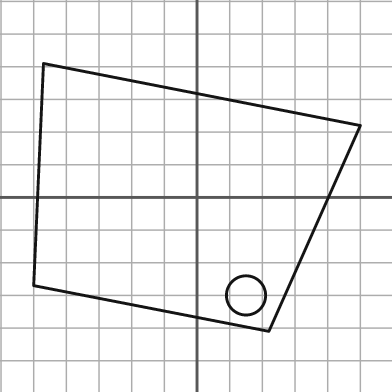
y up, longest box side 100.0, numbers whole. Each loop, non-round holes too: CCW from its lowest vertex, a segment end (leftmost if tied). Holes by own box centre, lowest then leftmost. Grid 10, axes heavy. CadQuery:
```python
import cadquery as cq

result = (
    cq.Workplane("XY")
    .moveTo(22.0, -41.0)
    .lineTo(50.0, 22.0)
    .lineTo(-47.0, 41.0)
    .lineTo(-50.0, -27.0)
    .close()
    .moveTo(15.0, -30.0)
    .circle(6.0)
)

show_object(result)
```